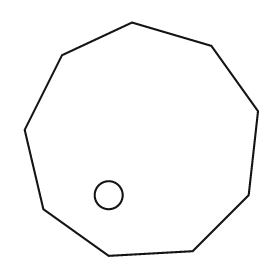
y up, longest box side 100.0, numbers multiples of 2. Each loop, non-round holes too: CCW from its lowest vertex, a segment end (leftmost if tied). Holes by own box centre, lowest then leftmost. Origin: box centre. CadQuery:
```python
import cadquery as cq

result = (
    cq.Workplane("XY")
    .moveTo(-14.0, -50.0)
    .lineTo(22.0, -48.0)
    .lineTo(46.0, -24.0)
    .lineTo(50.0, 12.0)
    .lineTo(30.0, 40.0)
    .lineTo(-4.0, 50.0)
    .lineTo(-34.0, 36.0)
    .lineTo(-50.0, 4.0)
    .lineTo(-42.0, -30.0)
    .close()
    .moveTo(-14.0, -24.0)
    .circle(6.0)
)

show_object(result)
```